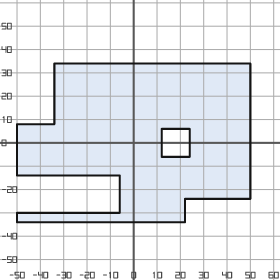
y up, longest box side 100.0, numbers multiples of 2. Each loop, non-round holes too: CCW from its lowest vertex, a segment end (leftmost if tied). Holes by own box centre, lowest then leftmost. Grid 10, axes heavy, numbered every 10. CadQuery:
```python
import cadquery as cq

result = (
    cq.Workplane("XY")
    .moveTo(-50.0, -34.0)
    .lineTo(22.0, -34.0)
    .lineTo(22.0, -24.0)
    .lineTo(50.0, -24.0)
    .lineTo(50.0, 34.0)
    .lineTo(-34.0, 34.0)
    .lineTo(-34.0, 8.0)
    .lineTo(-50.0, 8.0)
    .lineTo(-50.0, -14.0)
    .lineTo(-6.0, -14.0)
    .lineTo(-6.0, -30.0)
    .lineTo(-50.0, -30.0)
    .close()
    .moveTo(12.0, -6.0)
    .lineTo(24.0, -6.0)
    .lineTo(24.0, 6.0)
    .lineTo(12.0, 6.0)
    .close()
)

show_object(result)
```